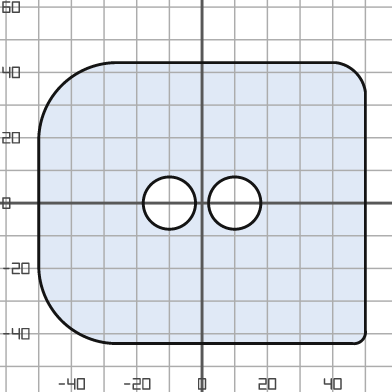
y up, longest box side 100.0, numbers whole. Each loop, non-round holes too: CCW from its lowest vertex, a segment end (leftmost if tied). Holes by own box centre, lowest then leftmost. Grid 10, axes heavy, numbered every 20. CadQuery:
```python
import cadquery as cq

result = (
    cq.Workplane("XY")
    .moveTo(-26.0, -43.0)
    .lineTo(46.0, -43.0)
    .threePointArc((49.0, -42.0), (50.0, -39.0))
    .lineTo(50.0, 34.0)
    .threePointArc((47.0, 40.0), (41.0, 43.0))
    .lineTo(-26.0, 43.0)
    .threePointArc((-43.0, 36.0), (-50.0, 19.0))
    .lineTo(-50.0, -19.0)
    .threePointArc((-43.0, -36.0), (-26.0, -43.0))
    .close()
    .moveTo(-10.0, 0.0)
    .circle(8.0)
    .moveTo(10.0, 0.0)
    .circle(8.0)
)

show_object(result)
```